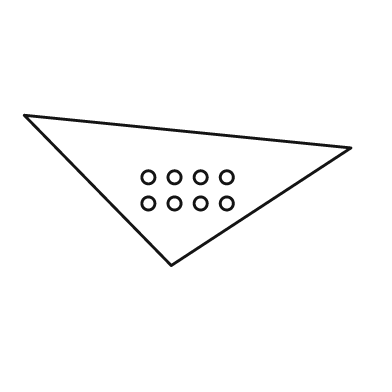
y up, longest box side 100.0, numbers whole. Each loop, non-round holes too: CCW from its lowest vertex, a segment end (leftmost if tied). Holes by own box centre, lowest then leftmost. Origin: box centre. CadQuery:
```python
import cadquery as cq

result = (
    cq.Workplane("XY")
    .moveTo(-5.0, -23.0)
    .lineTo(50.0, 13.0)
    .lineTo(-50.0, 23.0)
    .close()
    .moveTo(-12.0, -4.0)
    .circle(2.0)
    .moveTo(-4.0, -4.0)
    .circle(2.0)
    .moveTo(4.0, -4.0)
    .circle(2.0)
    .moveTo(12.0, -4.0)
    .circle(2.0)
    .moveTo(-12.0, 4.0)
    .circle(2.0)
    .moveTo(-4.0, 4.0)
    .circle(2.0)
    .moveTo(4.0, 4.0)
    .circle(2.0)
    .moveTo(12.0, 4.0)
    .circle(2.0)
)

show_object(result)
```